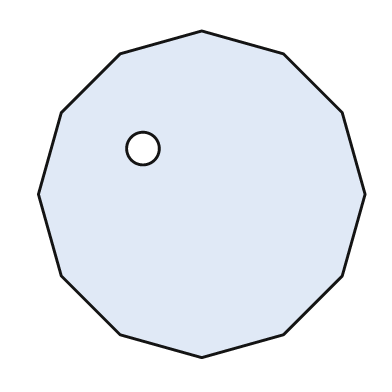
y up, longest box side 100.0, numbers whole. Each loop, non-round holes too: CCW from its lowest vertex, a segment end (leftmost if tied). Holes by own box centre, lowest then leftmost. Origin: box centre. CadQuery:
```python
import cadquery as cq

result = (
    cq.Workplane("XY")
    .moveTo(0.0, -50.0)
    .lineTo(25.0, -43.0)
    .lineTo(43.0, -25.0)
    .lineTo(50.0, 0.0)
    .lineTo(43.0, 25.0)
    .lineTo(25.0, 43.0)
    .lineTo(0.0, 50.0)
    .lineTo(-25.0, 43.0)
    .lineTo(-43.0, 25.0)
    .lineTo(-50.0, 0.0)
    .lineTo(-43.0, -25.0)
    .lineTo(-25.0, -43.0)
    .close()
    .moveTo(-18.0, 14.0)
    .circle(5.0)
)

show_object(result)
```